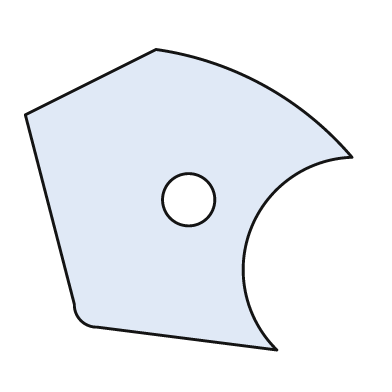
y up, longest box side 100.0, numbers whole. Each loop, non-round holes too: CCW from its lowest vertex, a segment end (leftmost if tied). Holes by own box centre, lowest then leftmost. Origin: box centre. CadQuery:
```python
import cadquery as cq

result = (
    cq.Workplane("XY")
    .moveTo(27.0, -46.0)
    .threePointArc((19.0, -9.0), (50.0, 13.0))
    .threePointArc((23.0, 35.0), (-10.0, 46.0))
    .lineTo(-50.0, 26.0)
    .lineTo(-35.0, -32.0)
    .threePointArc((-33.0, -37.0), (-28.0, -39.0))
    .close()
    .moveTo(0.0, 0.0)
    .circle(8.0)
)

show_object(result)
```